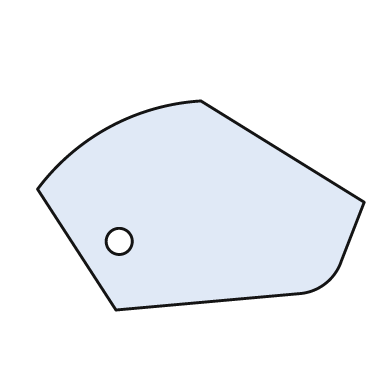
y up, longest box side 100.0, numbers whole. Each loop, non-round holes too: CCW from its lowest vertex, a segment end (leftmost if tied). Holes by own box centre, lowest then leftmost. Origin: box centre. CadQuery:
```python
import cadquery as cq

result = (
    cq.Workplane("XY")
    .moveTo(-26.0, -32.0)
    .lineTo(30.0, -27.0)
    .threePointArc((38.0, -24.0), (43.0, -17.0))
    .lineTo(50.0, 1.0)
    .lineTo(0.0, 32.0)
    .threePointArc((-28.0, 24.0), (-50.0, 5.0))
    .close()
    .moveTo(-25.0, -11.0)
    .circle(4.0)
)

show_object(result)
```